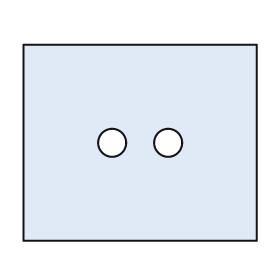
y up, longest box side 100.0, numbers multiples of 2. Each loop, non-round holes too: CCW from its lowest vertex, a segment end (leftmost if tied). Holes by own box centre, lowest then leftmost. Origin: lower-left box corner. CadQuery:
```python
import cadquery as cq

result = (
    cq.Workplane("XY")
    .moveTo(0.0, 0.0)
    .lineTo(100.0, 0.0)
    .lineTo(100.0, 84.0)
    .lineTo(0.0, 84.0)
    .close()
    .moveTo(38.0, 42.0)
    .circle(6.0)
    .moveTo(62.0, 42.0)
    .circle(6.0)
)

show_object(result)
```